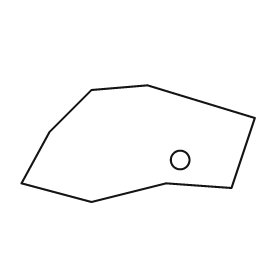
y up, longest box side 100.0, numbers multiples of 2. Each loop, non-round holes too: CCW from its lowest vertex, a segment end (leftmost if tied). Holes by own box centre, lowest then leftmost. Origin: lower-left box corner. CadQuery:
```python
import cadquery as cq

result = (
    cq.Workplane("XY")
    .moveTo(30.0, 0.0)
    .lineTo(62.0, 8.0)
    .lineTo(90.0, 6.0)
    .lineTo(100.0, 36.0)
    .lineTo(54.0, 50.0)
    .lineTo(30.0, 48.0)
    .lineTo(12.0, 30.0)
    .lineTo(0.0, 8.0)
    .close()
    .moveTo(68.0, 18.0)
    .circle(4.0)
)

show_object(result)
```